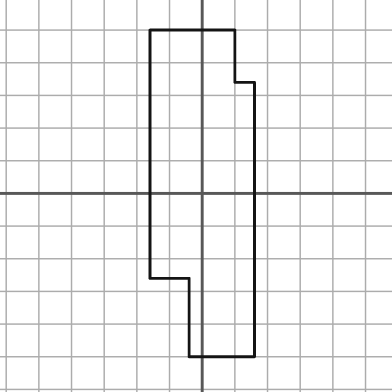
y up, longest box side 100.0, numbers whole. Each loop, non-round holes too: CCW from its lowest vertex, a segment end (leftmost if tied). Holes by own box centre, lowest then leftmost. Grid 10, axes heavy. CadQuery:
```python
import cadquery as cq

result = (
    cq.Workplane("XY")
    .moveTo(-4.0, -50.0)
    .lineTo(16.0, -50.0)
    .lineTo(16.0, 34.0)
    .lineTo(10.0, 34.0)
    .lineTo(10.0, 50.0)
    .lineTo(-16.0, 50.0)
    .lineTo(-16.0, -26.0)
    .lineTo(-4.0, -26.0)
    .close()
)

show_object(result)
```